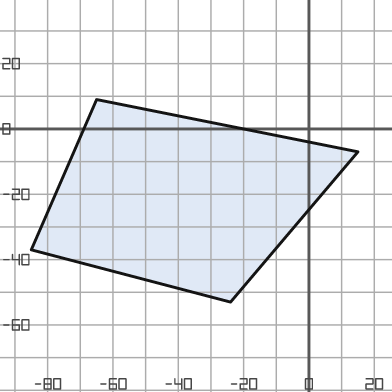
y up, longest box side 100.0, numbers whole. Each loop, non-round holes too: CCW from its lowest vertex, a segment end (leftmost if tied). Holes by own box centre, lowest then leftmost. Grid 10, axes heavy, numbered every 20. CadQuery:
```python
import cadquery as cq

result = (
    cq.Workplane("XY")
    .moveTo(-24.0, -53.0)
    .lineTo(15.0, -7.0)
    .lineTo(-65.0, 9.0)
    .lineTo(-85.0, -37.0)
    .close()
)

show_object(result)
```